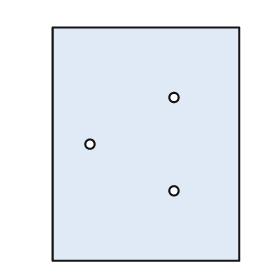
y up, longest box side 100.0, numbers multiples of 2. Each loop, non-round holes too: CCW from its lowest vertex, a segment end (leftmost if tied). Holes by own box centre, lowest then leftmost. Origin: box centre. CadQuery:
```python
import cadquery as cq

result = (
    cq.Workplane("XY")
    .moveTo(-40.0, -50.0)
    .lineTo(40.0, -50.0)
    .lineTo(40.0, 50.0)
    .lineTo(-40.0, 50.0)
    .close()
    .moveTo(12.0, -20.0)
    .circle(2.0)
    .moveTo(-24.0, 0.0)
    .circle(2.0)
    .moveTo(12.0, 20.0)
    .circle(2.0)
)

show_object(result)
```